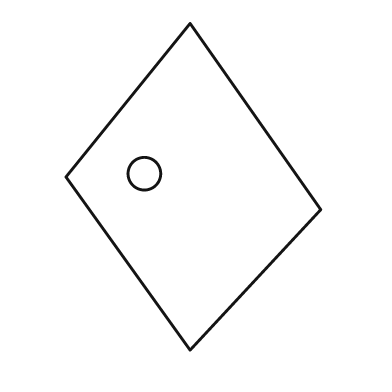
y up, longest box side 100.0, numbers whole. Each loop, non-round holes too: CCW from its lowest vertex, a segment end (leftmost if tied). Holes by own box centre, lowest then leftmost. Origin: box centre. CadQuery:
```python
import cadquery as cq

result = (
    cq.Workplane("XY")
    .moveTo(-1.0, -50.0)
    .lineTo(39.0, -7.0)
    .lineTo(-1.0, 50.0)
    .lineTo(-39.0, 3.0)
    .close()
    .moveTo(-15.0, 4.0)
    .circle(5.0)
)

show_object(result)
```